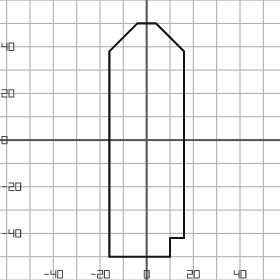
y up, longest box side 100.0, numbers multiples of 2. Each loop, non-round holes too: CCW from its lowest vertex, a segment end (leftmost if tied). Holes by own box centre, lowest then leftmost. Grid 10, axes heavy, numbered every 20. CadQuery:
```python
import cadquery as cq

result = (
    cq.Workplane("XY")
    .moveTo(-16.0, -50.0)
    .lineTo(10.0, -50.0)
    .lineTo(10.0, -42.0)
    .lineTo(16.0, -42.0)
    .lineTo(16.0, 38.0)
    .lineTo(4.0, 50.0)
    .lineTo(-4.0, 50.0)
    .lineTo(-16.0, 38.0)
    .close()
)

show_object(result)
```